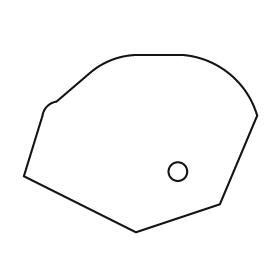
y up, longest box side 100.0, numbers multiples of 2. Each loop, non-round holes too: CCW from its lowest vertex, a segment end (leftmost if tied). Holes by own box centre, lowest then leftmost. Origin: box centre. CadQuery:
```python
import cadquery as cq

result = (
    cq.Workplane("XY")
    .moveTo(-2.0, -38.0)
    .lineTo(34.0, -26.0)
    .lineTo(50.0, 12.0)
    .threePointArc((38.0, 30.0), (18.0, 38.0))
    .lineTo(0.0, 38.0)
    .threePointArc((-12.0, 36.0), (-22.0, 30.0))
    .lineTo(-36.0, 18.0)
    .threePointArc((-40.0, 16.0), (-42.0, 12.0))
    .lineTo(-50.0, -14.0)
    .close()
    .moveTo(16.0, -12.0)
    .circle(4.0)
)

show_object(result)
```